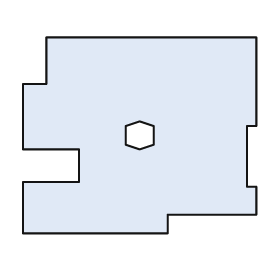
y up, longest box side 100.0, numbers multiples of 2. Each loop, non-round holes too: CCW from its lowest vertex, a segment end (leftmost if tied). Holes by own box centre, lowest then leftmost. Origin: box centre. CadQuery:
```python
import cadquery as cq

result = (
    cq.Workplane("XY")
    .moveTo(-50.0, -42.0)
    .lineTo(12.0, -42.0)
    .lineTo(12.0, -34.0)
    .lineTo(50.0, -34.0)
    .lineTo(50.0, -22.0)
    .lineTo(46.0, -22.0)
    .lineTo(46.0, 4.0)
    .lineTo(50.0, 4.0)
    .lineTo(50.0, 42.0)
    .lineTo(-40.0, 42.0)
    .lineTo(-40.0, 22.0)
    .lineTo(-50.0, 22.0)
    .lineTo(-50.0, -6.0)
    .lineTo(-26.0, -6.0)
    .lineTo(-26.0, -20.0)
    .lineTo(-50.0, -20.0)
    .close()
    .moveTo(0.0, -6.0)
    .lineTo(6.0, -4.0)
    .lineTo(6.0, 4.0)
    .lineTo(0.0, 6.0)
    .lineTo(-6.0, 4.0)
    .lineTo(-6.0, -4.0)
    .close()
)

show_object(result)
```